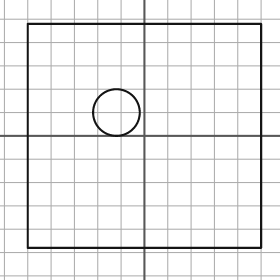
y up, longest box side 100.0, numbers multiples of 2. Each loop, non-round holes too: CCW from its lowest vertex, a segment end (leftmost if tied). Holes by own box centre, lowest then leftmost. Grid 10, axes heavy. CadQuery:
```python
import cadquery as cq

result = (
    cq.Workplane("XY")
    .moveTo(-50.0, -48.0)
    .lineTo(50.0, -48.0)
    .lineTo(50.0, 48.0)
    .lineTo(-50.0, 48.0)
    .close()
    .moveTo(-12.0, 10.0)
    .circle(10.0)
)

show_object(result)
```